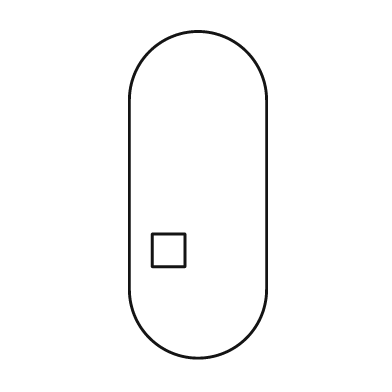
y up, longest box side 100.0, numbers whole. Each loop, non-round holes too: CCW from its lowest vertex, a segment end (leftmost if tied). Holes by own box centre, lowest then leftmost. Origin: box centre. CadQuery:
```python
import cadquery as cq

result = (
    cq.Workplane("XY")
    .moveTo(-21.0, -29.0)
    .threePointArc((0.0, -50.0), (21.0, -29.0))
    .lineTo(21.0, 29.0)
    .threePointArc((0.0, 50.0), (-21.0, 29.0))
    .close()
    .moveTo(-14.0, -22.0)
    .lineTo(-4.0, -22.0)
    .lineTo(-4.0, -12.0)
    .lineTo(-14.0, -12.0)
    .close()
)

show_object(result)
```